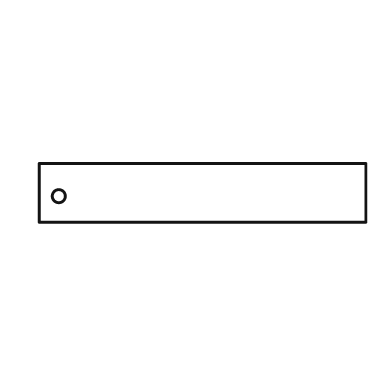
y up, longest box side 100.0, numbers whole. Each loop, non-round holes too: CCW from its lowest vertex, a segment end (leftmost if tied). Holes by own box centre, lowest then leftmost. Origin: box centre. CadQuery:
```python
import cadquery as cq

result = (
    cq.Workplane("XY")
    .moveTo(-50.0, -9.0)
    .lineTo(50.0, -9.0)
    .lineTo(50.0, 9.0)
    .lineTo(-50.0, 9.0)
    .close()
    .moveTo(-44.0, -1.0)
    .circle(2.0)
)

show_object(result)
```